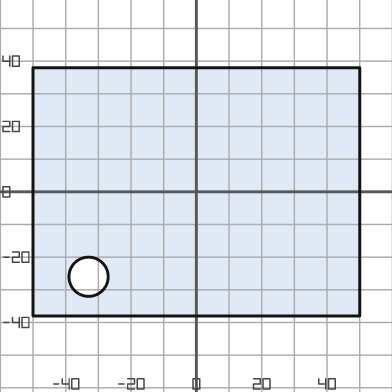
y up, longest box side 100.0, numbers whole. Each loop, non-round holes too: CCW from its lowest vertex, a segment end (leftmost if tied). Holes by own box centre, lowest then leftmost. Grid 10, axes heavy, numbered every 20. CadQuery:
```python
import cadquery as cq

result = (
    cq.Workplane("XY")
    .moveTo(-50.0, -38.0)
    .lineTo(50.0, -38.0)
    .lineTo(50.0, 38.0)
    .lineTo(-50.0, 38.0)
    .close()
    .moveTo(-33.0, -26.0)
    .circle(6.0)
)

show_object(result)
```